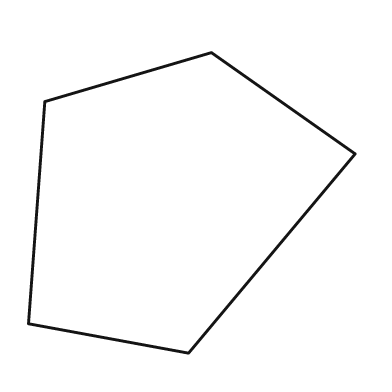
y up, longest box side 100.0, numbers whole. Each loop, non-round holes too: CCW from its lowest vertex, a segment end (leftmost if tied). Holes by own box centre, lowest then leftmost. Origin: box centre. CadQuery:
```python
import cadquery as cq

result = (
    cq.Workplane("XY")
    .moveTo(-1.0, -46.0)
    .lineTo(50.0, 15.0)
    .lineTo(6.0, 46.0)
    .lineTo(-45.0, 31.0)
    .lineTo(-50.0, -37.0)
    .close()
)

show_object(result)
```